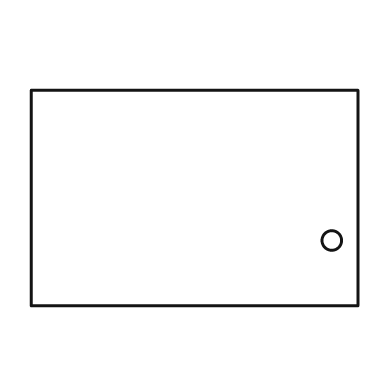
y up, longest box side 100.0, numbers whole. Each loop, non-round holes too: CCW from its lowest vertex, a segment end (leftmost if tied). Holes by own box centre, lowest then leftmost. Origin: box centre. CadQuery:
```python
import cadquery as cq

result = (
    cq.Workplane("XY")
    .moveTo(-50.0, -33.0)
    .lineTo(50.0, -33.0)
    .lineTo(50.0, 33.0)
    .lineTo(-50.0, 33.0)
    .close()
    .moveTo(42.0, -13.0)
    .circle(3.0)
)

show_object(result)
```